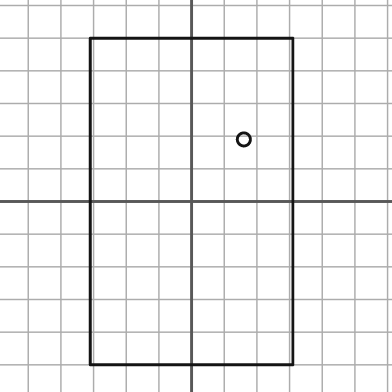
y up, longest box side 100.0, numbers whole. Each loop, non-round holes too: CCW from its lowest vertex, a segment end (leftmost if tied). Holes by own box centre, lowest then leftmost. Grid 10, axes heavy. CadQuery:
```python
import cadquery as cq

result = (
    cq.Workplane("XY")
    .moveTo(-31.0, -50.0)
    .lineTo(31.0, -50.0)
    .lineTo(31.0, 50.0)
    .lineTo(-31.0, 50.0)
    .close()
    .moveTo(16.0, 19.0)
    .circle(2.0)
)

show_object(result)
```